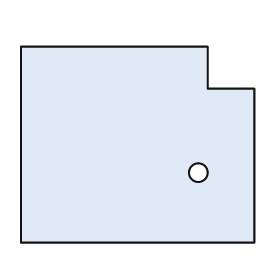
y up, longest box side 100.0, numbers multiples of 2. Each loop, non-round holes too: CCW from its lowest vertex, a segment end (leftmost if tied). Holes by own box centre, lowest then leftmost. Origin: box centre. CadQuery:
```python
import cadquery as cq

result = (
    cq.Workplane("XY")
    .moveTo(-50.0, -42.0)
    .lineTo(50.0, -42.0)
    .lineTo(50.0, 24.0)
    .lineTo(30.0, 24.0)
    .lineTo(30.0, 42.0)
    .lineTo(-50.0, 42.0)
    .close()
    .moveTo(26.0, -12.0)
    .circle(4.0)
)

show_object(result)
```